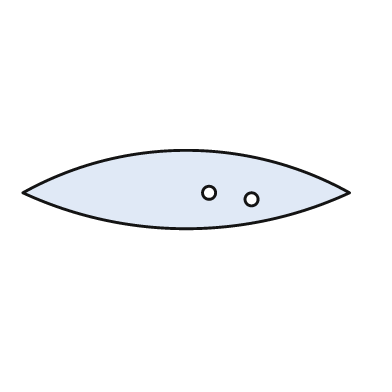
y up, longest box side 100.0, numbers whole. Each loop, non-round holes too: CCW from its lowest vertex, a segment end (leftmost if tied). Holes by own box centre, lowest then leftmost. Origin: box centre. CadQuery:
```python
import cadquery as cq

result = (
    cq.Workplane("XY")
    .moveTo(-50.0, -1.0)
    .threePointArc((0.0, -12.0), (50.0, -1.0))
    .threePointArc((0.0, 12.0), (-50.0, -1.0))
    .close()
    .moveTo(20.0, -3.0)
    .circle(2.0)
    .moveTo(7.0, -1.0)
    .circle(2.0)
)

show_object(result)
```